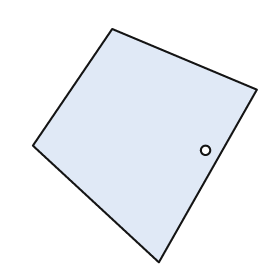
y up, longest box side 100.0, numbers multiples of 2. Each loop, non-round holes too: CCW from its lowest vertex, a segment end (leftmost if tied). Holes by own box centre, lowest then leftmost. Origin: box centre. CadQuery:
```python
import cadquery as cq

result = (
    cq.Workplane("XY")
    .moveTo(6.0, -50.0)
    .lineTo(48.0, 24.0)
    .lineTo(-14.0, 50.0)
    .lineTo(-48.0, 0.0)
    .close()
    .moveTo(26.0, -2.0)
    .circle(2.0)
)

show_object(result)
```